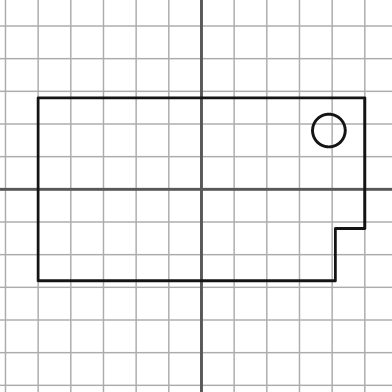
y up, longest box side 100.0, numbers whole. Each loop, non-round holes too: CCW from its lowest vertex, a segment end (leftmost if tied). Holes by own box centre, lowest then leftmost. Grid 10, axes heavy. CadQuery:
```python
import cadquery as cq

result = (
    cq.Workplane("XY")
    .moveTo(-50.0, -28.0)
    .lineTo(41.0, -28.0)
    .lineTo(41.0, -12.0)
    .lineTo(50.0, -12.0)
    .lineTo(50.0, 28.0)
    .lineTo(-50.0, 28.0)
    .close()
    .moveTo(39.0, 18.0)
    .circle(5.0)
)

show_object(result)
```